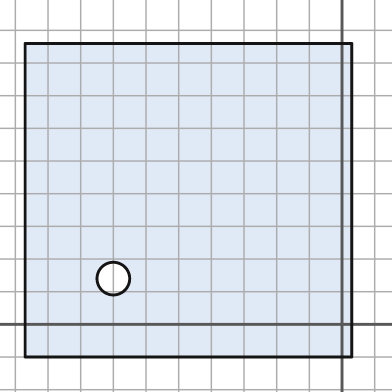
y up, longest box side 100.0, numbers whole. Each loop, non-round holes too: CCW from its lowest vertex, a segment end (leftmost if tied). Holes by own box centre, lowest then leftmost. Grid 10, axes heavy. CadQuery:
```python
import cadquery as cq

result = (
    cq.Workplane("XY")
    .moveTo(-97.0, -10.0)
    .lineTo(3.0, -10.0)
    .lineTo(3.0, 86.0)
    .lineTo(-97.0, 86.0)
    .close()
    .moveTo(-70.0, 14.0)
    .circle(5.0)
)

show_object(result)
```